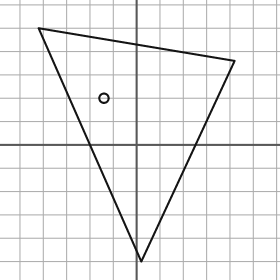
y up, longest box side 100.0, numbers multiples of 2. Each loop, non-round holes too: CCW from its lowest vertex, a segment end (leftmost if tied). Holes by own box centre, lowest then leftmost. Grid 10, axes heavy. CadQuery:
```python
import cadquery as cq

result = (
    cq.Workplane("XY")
    .moveTo(2.0, -50.0)
    .lineTo(42.0, 36.0)
    .lineTo(-42.0, 50.0)
    .close()
    .moveTo(-14.0, 20.0)
    .circle(2.0)
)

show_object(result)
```